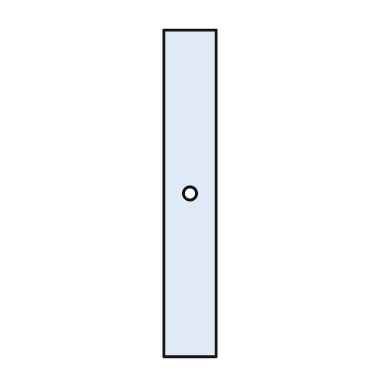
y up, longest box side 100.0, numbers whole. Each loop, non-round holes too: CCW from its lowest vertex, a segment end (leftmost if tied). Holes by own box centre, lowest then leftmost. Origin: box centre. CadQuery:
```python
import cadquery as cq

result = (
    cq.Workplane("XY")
    .moveTo(-8.0, -50.0)
    .lineTo(8.0, -50.0)
    .lineTo(8.0, 50.0)
    .lineTo(-8.0, 50.0)
    .close()
    .moveTo(0.0, 0.0)
    .circle(2.0)
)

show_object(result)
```